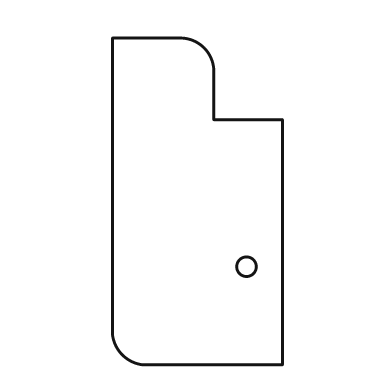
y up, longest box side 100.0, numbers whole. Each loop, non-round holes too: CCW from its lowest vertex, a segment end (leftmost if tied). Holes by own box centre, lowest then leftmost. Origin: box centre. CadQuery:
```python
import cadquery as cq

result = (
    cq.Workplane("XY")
    .moveTo(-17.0, -50.0)
    .lineTo(26.0, -50.0)
    .lineTo(26.0, 25.0)
    .lineTo(5.0, 25.0)
    .lineTo(5.0, 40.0)
    .threePointArc((2.0, 47.0), (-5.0, 50.0))
    .lineTo(-26.0, 50.0)
    .lineTo(-26.0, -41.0)
    .threePointArc((-23.0, -47.0), (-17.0, -50.0))
    .close()
    .moveTo(15.0, -20.0)
    .circle(3.0)
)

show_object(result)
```